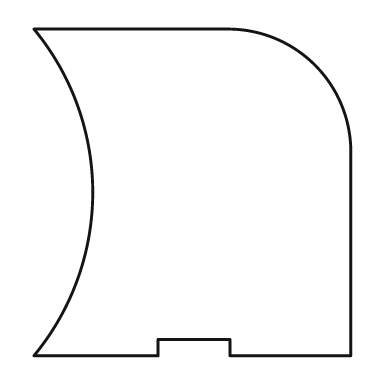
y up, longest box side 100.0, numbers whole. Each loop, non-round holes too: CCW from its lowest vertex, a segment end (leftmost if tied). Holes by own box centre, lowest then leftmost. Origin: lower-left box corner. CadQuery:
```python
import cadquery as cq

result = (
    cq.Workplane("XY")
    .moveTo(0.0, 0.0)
    .lineTo(38.0, 0.0)
    .lineTo(38.0, 5.0)
    .lineTo(60.0, 5.0)
    .lineTo(60.0, 0.0)
    .lineTo(97.0, 0.0)
    .lineTo(97.0, 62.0)
    .threePointArc((86.0, 89.0), (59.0, 100.0))
    .lineTo(0.0, 100.0)
    .threePointArc((18.0, 50.0), (0.0, 0.0))
    .close()
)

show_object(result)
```